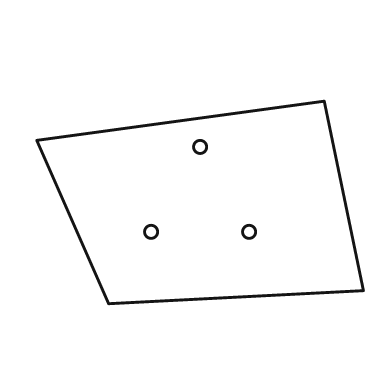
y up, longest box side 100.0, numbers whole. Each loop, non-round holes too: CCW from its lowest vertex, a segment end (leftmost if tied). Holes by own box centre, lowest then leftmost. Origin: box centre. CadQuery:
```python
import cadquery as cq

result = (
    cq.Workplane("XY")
    .moveTo(-28.0, -31.0)
    .lineTo(50.0, -27.0)
    .lineTo(38.0, 31.0)
    .lineTo(-50.0, 19.0)
    .close()
    .moveTo(-15.0, -9.0)
    .circle(2.0)
    .moveTo(15.0, -9.0)
    .circle(2.0)
    .moveTo(0.0, 17.0)
    .circle(2.0)
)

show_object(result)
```